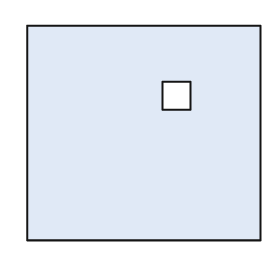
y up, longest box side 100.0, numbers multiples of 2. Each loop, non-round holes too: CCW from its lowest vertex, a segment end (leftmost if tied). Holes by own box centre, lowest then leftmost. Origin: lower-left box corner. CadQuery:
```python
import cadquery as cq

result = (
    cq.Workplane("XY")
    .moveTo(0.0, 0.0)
    .lineTo(100.0, 0.0)
    .lineTo(100.0, 92.0)
    .lineTo(0.0, 92.0)
    .close()
    .moveTo(58.0, 56.0)
    .lineTo(70.0, 56.0)
    .lineTo(70.0, 68.0)
    .lineTo(58.0, 68.0)
    .close()
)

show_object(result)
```